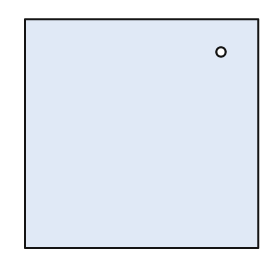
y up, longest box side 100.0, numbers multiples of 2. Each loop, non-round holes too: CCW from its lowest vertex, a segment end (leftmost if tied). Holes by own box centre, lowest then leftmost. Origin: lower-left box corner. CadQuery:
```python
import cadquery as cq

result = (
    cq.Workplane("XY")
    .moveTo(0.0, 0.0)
    .lineTo(100.0, 0.0)
    .lineTo(100.0, 98.0)
    .lineTo(0.0, 98.0)
    .close()
    .moveTo(84.0, 84.0)
    .circle(2.0)
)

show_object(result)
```